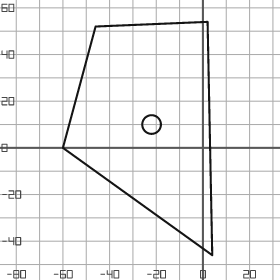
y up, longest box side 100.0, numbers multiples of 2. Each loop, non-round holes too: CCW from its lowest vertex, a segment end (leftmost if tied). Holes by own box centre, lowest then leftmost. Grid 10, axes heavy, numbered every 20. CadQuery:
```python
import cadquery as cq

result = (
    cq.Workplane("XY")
    .moveTo(4.0, -46.0)
    .lineTo(2.0, 54.0)
    .lineTo(-46.0, 52.0)
    .lineTo(-60.0, 0.0)
    .close()
    .moveTo(-22.0, 10.0)
    .circle(4.0)
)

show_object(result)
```